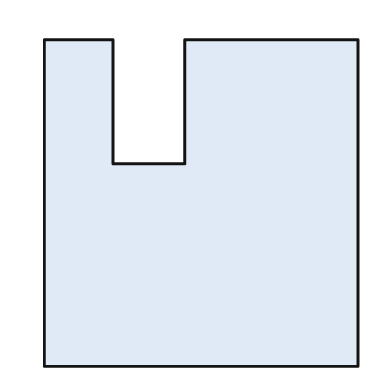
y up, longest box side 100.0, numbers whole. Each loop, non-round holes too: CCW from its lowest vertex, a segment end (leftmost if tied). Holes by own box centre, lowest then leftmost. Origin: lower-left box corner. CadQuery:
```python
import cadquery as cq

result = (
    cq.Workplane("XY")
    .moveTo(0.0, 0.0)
    .lineTo(96.0, 0.0)
    .lineTo(96.0, 100.0)
    .lineTo(43.0, 100.0)
    .lineTo(43.0, 62.0)
    .lineTo(21.0, 62.0)
    .lineTo(21.0, 100.0)
    .lineTo(0.0, 100.0)
    .close()
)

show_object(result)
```